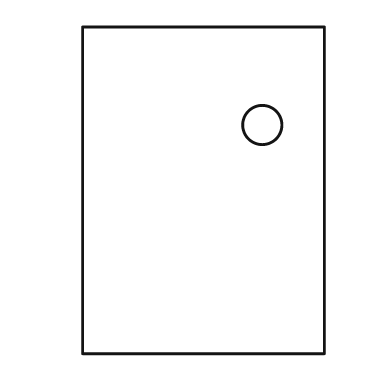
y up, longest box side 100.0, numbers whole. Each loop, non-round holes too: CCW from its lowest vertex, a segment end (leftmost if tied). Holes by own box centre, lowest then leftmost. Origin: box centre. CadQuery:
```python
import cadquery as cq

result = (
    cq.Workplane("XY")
    .moveTo(-37.0, -50.0)
    .lineTo(37.0, -50.0)
    .lineTo(37.0, 50.0)
    .lineTo(-37.0, 50.0)
    .close()
    .moveTo(18.0, 20.0)
    .circle(6.0)
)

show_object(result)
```